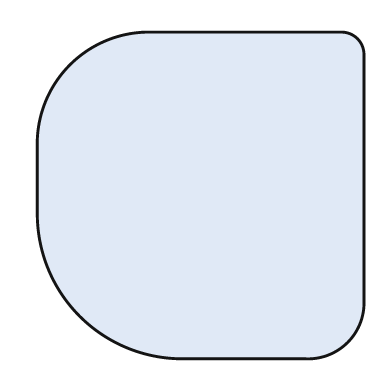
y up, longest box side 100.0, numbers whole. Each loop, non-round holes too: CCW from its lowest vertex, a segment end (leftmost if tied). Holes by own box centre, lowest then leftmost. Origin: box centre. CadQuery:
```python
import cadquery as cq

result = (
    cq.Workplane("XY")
    .moveTo(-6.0, -50.0)
    .lineTo(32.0, -50.0)
    .threePointArc((45.0, -45.0), (50.0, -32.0))
    .lineTo(50.0, 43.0)
    .threePointArc((48.0, 48.0), (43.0, 50.0))
    .lineTo(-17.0, 50.0)
    .threePointArc((-40.0, 40.0), (-50.0, 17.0))
    .lineTo(-50.0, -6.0)
    .threePointArc((-37.0, -37.0), (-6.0, -50.0))
    .close()
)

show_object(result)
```